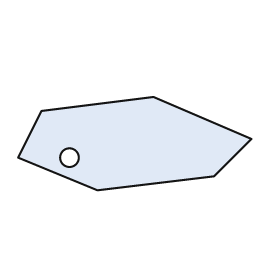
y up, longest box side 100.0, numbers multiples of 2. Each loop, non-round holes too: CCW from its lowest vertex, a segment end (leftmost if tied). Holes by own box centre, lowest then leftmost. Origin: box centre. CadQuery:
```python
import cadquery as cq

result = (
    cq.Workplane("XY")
    .moveTo(-16.0, -20.0)
    .lineTo(34.0, -14.0)
    .lineTo(50.0, 2.0)
    .lineTo(8.0, 20.0)
    .lineTo(-40.0, 14.0)
    .lineTo(-50.0, -6.0)
    .close()
    .moveTo(-28.0, -6.0)
    .circle(4.0)
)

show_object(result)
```